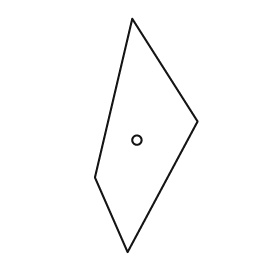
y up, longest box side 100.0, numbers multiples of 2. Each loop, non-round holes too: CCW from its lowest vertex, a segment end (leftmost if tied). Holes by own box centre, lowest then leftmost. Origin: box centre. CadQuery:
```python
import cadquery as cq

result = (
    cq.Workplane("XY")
    .moveTo(-8.0, -50.0)
    .lineTo(22.0, 6.0)
    .lineTo(-6.0, 50.0)
    .lineTo(-22.0, -18.0)
    .close()
    .moveTo(-4.0, -2.0)
    .circle(2.0)
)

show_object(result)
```